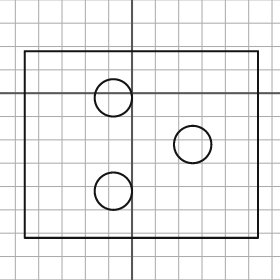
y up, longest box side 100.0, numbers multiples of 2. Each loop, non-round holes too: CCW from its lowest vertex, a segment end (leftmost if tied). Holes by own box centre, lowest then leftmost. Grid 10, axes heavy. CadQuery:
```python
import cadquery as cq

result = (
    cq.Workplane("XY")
    .moveTo(-46.0, -62.0)
    .lineTo(54.0, -62.0)
    .lineTo(54.0, 18.0)
    .lineTo(-46.0, 18.0)
    .close()
    .moveTo(-8.0, -42.0)
    .circle(8.0)
    .moveTo(26.0, -22.0)
    .circle(8.0)
    .moveTo(-8.0, -2.0)
    .circle(8.0)
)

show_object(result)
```